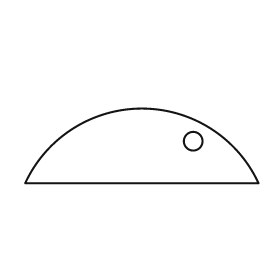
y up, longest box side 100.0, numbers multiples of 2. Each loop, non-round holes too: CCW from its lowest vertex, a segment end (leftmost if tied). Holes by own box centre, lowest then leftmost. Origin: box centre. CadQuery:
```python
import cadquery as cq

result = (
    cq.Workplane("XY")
    .moveTo(-50.0, -16.0)
    .lineTo(50.0, -16.0)
    .threePointArc((0.0, 16.0), (-50.0, -16.0))
    .close()
    .moveTo(22.0, 2.0)
    .circle(4.0)
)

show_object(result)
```